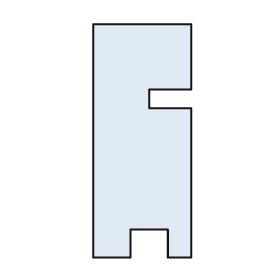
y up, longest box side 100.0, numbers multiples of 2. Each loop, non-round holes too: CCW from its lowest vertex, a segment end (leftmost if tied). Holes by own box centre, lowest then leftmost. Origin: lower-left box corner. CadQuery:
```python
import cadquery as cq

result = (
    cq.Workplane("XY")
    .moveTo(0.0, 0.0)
    .lineTo(16.0, 0.0)
    .lineTo(16.0, 12.0)
    .lineTo(32.0, 12.0)
    .lineTo(32.0, 0.0)
    .lineTo(42.0, 0.0)
    .lineTo(42.0, 64.0)
    .lineTo(24.0, 64.0)
    .lineTo(24.0, 72.0)
    .lineTo(42.0, 72.0)
    .lineTo(42.0, 100.0)
    .lineTo(0.0, 100.0)
    .close()
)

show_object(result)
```